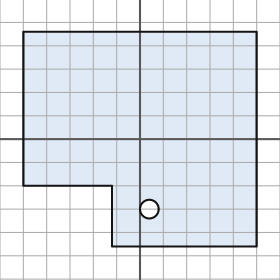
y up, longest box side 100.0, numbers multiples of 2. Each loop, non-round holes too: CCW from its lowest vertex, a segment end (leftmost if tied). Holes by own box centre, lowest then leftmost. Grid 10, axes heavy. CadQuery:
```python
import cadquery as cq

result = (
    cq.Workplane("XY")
    .moveTo(-12.0, -46.0)
    .lineTo(50.0, -46.0)
    .lineTo(50.0, 46.0)
    .lineTo(-50.0, 46.0)
    .lineTo(-50.0, -20.0)
    .lineTo(-12.0, -20.0)
    .close()
    .moveTo(4.0, -30.0)
    .circle(4.0)
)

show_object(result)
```